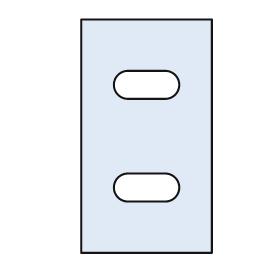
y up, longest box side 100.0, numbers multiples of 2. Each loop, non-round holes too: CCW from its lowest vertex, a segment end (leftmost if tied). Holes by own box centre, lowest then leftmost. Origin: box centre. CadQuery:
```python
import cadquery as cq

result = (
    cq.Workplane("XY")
    .moveTo(-28.0, -50.0)
    .lineTo(28.0, -50.0)
    .lineTo(28.0, 50.0)
    .lineTo(-28.0, 50.0)
    .close()
    .moveTo(-8.0, -28.0)
    .lineTo(8.0, -28.0)
    .threePointArc((14.0, -22.0), (8.0, -16.0))
    .lineTo(-8.0, -16.0)
    .threePointArc((-14.0, -22.0), (-8.0, -28.0))
    .close()
    .moveTo(-8.0, 16.0)
    .lineTo(8.0, 16.0)
    .threePointArc((14.0, 22.0), (8.0, 28.0))
    .lineTo(-8.0, 28.0)
    .threePointArc((-14.0, 22.0), (-8.0, 16.0))
    .close()
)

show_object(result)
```